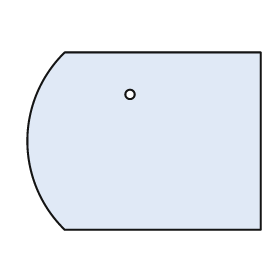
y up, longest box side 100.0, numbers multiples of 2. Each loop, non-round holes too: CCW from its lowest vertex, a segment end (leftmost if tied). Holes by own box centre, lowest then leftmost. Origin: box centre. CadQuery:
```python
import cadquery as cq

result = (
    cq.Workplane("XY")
    .moveTo(-34.0, -38.0)
    .lineTo(50.0, -38.0)
    .lineTo(50.0, 38.0)
    .lineTo(-34.0, 38.0)
    .threePointArc((-50.0, 0.0), (-34.0, -38.0))
    .close()
    .moveTo(-6.0, 20.0)
    .circle(2.0)
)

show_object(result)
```